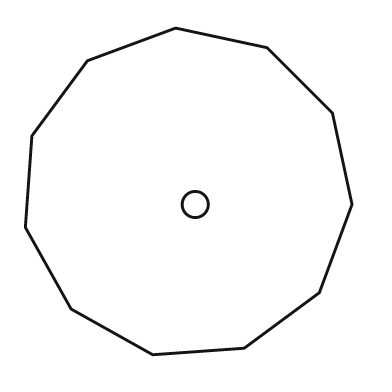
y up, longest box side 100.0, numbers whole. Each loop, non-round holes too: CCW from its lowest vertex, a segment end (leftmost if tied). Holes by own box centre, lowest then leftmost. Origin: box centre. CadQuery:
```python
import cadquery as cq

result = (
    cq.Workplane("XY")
    .moveTo(-11.0, -50.0)
    .lineTo(17.0, -48.0)
    .lineTo(40.0, -31.0)
    .lineTo(50.0, -4.0)
    .lineTo(44.0, 24.0)
    .lineTo(24.0, 44.0)
    .lineTo(-4.0, 50.0)
    .lineTo(-31.0, 40.0)
    .lineTo(-48.0, 17.0)
    .lineTo(-50.0, -11.0)
    .lineTo(-36.0, -36.0)
    .close()
    .moveTo(2.0, -4.0)
    .circle(4.0)
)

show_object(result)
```